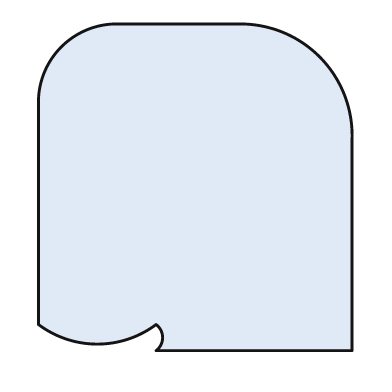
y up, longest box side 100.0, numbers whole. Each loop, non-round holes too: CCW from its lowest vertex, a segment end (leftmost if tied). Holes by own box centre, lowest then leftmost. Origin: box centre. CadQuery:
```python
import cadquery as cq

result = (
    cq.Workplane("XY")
    .moveTo(-12.0, -50.0)
    .lineTo(48.0, -50.0)
    .lineTo(48.0, 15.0)
    .threePointArc((38.0, 40.0), (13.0, 50.0))
    .lineTo(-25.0, 50.0)
    .threePointArc((-41.0, 43.0), (-48.0, 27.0))
    .lineTo(-48.0, -42.0)
    .threePointArc((-30.0, -48.0), (-12.0, -42.0))
    .threePointArc((-10.0, -46.0), (-12.0, -50.0))
    .close()
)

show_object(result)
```